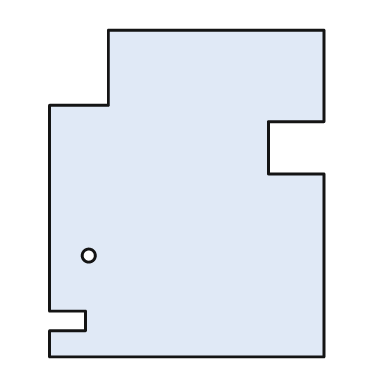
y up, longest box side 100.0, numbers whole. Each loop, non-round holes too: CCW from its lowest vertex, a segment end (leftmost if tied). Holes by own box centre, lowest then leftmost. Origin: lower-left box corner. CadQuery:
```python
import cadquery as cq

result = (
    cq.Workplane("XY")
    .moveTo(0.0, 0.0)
    .lineTo(84.0, 0.0)
    .lineTo(84.0, 56.0)
    .lineTo(67.0, 56.0)
    .lineTo(67.0, 72.0)
    .lineTo(84.0, 72.0)
    .lineTo(84.0, 100.0)
    .lineTo(18.0, 100.0)
    .lineTo(18.0, 77.0)
    .lineTo(0.0, 77.0)
    .lineTo(0.0, 14.0)
    .lineTo(11.0, 14.0)
    .lineTo(11.0, 8.0)
    .lineTo(0.0, 8.0)
    .close()
    .moveTo(12.0, 31.0)
    .circle(2.0)
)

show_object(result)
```